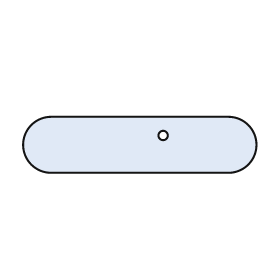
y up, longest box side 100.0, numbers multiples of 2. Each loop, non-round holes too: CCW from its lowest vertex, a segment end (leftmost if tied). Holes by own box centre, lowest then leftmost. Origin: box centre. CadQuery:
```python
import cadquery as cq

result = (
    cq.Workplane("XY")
    .moveTo(-38.0, -12.0)
    .lineTo(38.0, -12.0)
    .threePointArc((50.0, 0.0), (38.0, 12.0))
    .lineTo(-38.0, 12.0)
    .threePointArc((-50.0, 0.0), (-38.0, -12.0))
    .close()
    .moveTo(10.0, 4.0)
    .circle(2.0)
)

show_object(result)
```